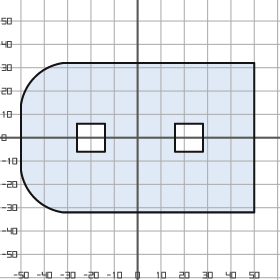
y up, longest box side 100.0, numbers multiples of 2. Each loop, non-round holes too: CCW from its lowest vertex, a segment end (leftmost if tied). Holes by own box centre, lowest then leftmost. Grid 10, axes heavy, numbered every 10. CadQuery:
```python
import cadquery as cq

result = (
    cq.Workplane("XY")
    .moveTo(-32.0, -32.0)
    .lineTo(50.0, -32.0)
    .lineTo(50.0, 32.0)
    .lineTo(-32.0, 32.0)
    .threePointArc((-44.0, 26.0), (-50.0, 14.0))
    .lineTo(-50.0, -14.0)
    .threePointArc((-44.0, -26.0), (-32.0, -32.0))
    .close()
    .moveTo(-26.0, -6.0)
    .lineTo(-14.0, -6.0)
    .lineTo(-14.0, 6.0)
    .lineTo(-26.0, 6.0)
    .close()
    .moveTo(16.0, -6.0)
    .lineTo(28.0, -6.0)
    .lineTo(28.0, 6.0)
    .lineTo(16.0, 6.0)
    .close()
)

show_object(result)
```